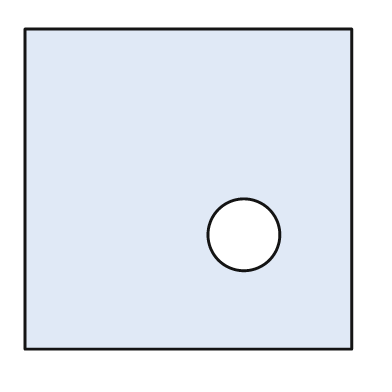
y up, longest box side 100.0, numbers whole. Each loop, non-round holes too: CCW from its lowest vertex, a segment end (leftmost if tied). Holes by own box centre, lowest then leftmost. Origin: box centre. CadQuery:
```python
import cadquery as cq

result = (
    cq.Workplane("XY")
    .moveTo(-50.0, -49.0)
    .lineTo(50.0, -49.0)
    .lineTo(50.0, 49.0)
    .lineTo(-50.0, 49.0)
    .close()
    .moveTo(17.0, -14.0)
    .circle(11.0)
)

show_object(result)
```